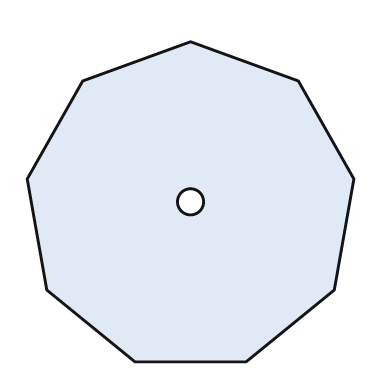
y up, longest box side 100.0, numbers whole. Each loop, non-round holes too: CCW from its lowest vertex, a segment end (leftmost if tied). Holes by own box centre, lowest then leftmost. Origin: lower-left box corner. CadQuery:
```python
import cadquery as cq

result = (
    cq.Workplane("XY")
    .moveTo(33.0, 0.0)
    .lineTo(67.0, 0.0)
    .lineTo(94.0, 22.0)
    .lineTo(100.0, 56.0)
    .lineTo(83.0, 86.0)
    .lineTo(50.0, 98.0)
    .lineTo(17.0, 86.0)
    .lineTo(0.0, 56.0)
    .lineTo(6.0, 22.0)
    .close()
    .moveTo(50.0, 49.0)
    .circle(4.0)
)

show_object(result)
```